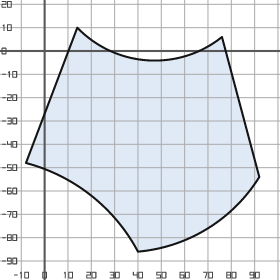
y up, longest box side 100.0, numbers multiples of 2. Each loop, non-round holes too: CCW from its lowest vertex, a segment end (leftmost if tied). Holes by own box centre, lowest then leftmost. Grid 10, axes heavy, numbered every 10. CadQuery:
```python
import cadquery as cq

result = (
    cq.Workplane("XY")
    .moveTo(40.0, -86.0)
    .threePointArc((70.0, -76.0), (92.0, -54.0))
    .lineTo(76.0, 6.0)
    .threePointArc((44.0, -4.0), (14.0, 10.0))
    .lineTo(-8.0, -48.0)
    .threePointArc((20.0, -62.0), (40.0, -86.0))
    .close()
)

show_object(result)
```